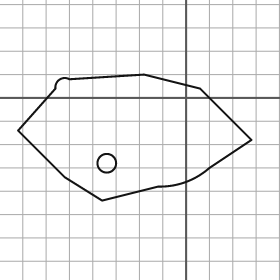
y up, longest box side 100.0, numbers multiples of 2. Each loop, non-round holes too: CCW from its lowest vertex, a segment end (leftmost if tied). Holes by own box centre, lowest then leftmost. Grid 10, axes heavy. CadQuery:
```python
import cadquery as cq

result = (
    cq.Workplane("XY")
    .moveTo(-36.0, -44.0)
    .lineTo(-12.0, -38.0)
    .threePointArc((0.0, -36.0), (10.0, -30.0))
    .lineTo(28.0, -18.0)
    .lineTo(6.0, 4.0)
    .lineTo(-18.0, 10.0)
    .lineTo(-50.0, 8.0)
    .threePointArc((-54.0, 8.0), (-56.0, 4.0))
    .lineTo(-72.0, -14.0)
    .lineTo(-52.0, -34.0)
    .close()
    .moveTo(-34.0, -28.0)
    .circle(4.0)
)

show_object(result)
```